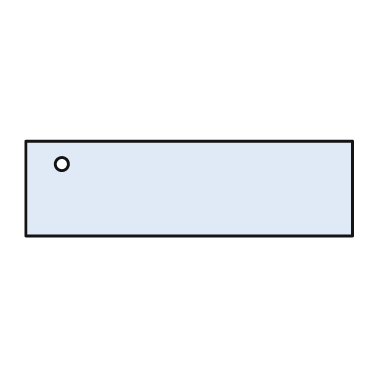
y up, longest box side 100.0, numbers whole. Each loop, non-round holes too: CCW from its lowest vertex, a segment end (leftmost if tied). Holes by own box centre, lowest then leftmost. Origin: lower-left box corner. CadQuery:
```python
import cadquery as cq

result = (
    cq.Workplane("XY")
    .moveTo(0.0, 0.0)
    .lineTo(100.0, 0.0)
    .lineTo(100.0, 29.0)
    .lineTo(0.0, 29.0)
    .close()
    .moveTo(11.0, 22.0)
    .circle(2.0)
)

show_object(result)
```